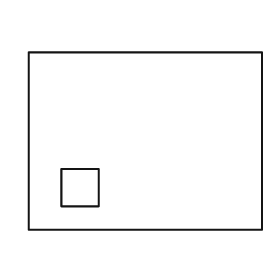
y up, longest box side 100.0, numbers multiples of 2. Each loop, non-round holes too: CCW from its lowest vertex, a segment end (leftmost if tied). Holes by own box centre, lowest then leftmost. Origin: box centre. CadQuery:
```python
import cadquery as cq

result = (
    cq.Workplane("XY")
    .moveTo(-50.0, -38.0)
    .lineTo(50.0, -38.0)
    .lineTo(50.0, 38.0)
    .lineTo(-50.0, 38.0)
    .close()
    .moveTo(-36.0, -28.0)
    .lineTo(-20.0, -28.0)
    .lineTo(-20.0, -12.0)
    .lineTo(-36.0, -12.0)
    .close()
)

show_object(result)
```